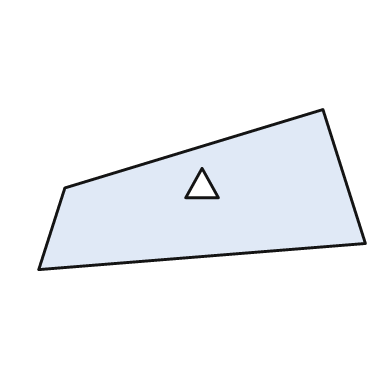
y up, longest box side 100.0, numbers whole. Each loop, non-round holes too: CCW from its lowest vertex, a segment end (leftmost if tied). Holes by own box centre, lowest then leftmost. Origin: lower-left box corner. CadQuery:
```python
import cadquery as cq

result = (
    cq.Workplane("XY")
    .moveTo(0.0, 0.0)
    .lineTo(100.0, 8.0)
    .lineTo(87.0, 49.0)
    .lineTo(8.0, 25.0)
    .close()
    .moveTo(45.0, 22.0)
    .lineTo(55.0, 22.0)
    .lineTo(50.0, 31.0)
    .close()
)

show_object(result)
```